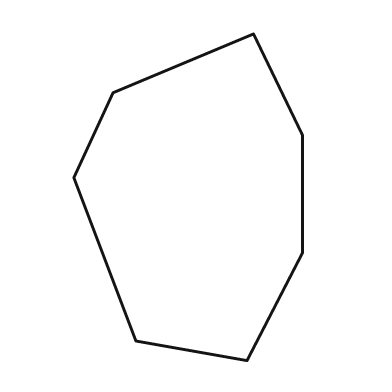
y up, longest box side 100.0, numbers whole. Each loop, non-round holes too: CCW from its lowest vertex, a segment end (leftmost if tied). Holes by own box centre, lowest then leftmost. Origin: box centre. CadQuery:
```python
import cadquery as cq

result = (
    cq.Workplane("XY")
    .moveTo(18.0, -50.0)
    .lineTo(35.0, -17.0)
    .lineTo(35.0, 19.0)
    .lineTo(20.0, 50.0)
    .lineTo(-23.0, 32.0)
    .lineTo(-35.0, 6.0)
    .lineTo(-16.0, -44.0)
    .close()
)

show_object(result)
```